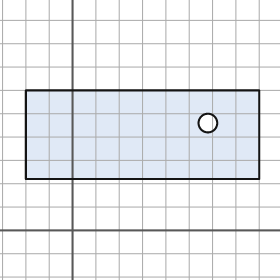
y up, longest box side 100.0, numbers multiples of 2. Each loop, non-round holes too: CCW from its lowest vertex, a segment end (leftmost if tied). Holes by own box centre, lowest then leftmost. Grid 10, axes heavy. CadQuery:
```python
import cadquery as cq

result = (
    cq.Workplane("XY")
    .moveTo(-20.0, 22.0)
    .lineTo(80.0, 22.0)
    .lineTo(80.0, 60.0)
    .lineTo(-20.0, 60.0)
    .close()
    .moveTo(58.0, 46.0)
    .circle(4.0)
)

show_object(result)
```